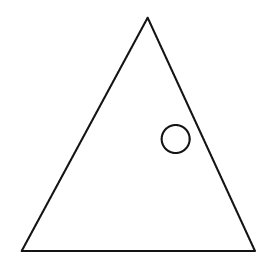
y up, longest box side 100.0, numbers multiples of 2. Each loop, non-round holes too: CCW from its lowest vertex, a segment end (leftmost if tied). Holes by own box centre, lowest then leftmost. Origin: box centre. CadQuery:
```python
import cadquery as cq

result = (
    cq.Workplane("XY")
    .moveTo(-50.0, -50.0)
    .lineTo(50.0, -50.0)
    .lineTo(4.0, 50.0)
    .close()
    .moveTo(16.0, -2.0)
    .circle(6.0)
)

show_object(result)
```